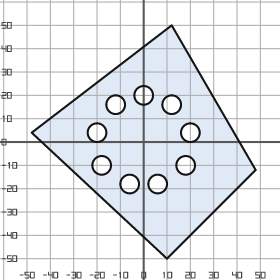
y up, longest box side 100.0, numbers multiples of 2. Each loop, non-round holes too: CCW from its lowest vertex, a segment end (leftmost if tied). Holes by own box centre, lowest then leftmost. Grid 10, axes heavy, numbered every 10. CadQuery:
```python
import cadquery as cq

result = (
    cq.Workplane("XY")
    .moveTo(10.0, -50.0)
    .lineTo(48.0, -12.0)
    .lineTo(12.0, 50.0)
    .lineTo(-48.0, 4.0)
    .close()
    .moveTo(-6.0, -18.0)
    .circle(4.0)
    .moveTo(6.0, -18.0)
    .circle(4.0)
    .moveTo(-18.0, -10.0)
    .circle(4.0)
    .moveTo(18.0, -10.0)
    .circle(4.0)
    .moveTo(-20.0, 4.0)
    .circle(4.0)
    .moveTo(20.0, 4.0)
    .circle(4.0)
    .moveTo(-12.0, 16.0)
    .circle(4.0)
    .moveTo(12.0, 16.0)
    .circle(4.0)
    .moveTo(0.0, 20.0)
    .circle(4.0)
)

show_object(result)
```